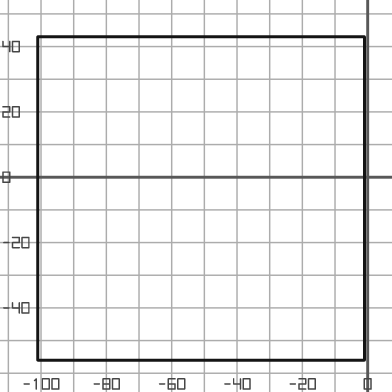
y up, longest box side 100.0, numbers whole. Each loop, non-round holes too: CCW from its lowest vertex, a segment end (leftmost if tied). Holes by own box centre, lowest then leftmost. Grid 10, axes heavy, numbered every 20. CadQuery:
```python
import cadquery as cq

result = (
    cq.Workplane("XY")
    .moveTo(-101.0, -56.0)
    .lineTo(-1.0, -56.0)
    .lineTo(-1.0, 43.0)
    .lineTo(-101.0, 43.0)
    .close()
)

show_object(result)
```